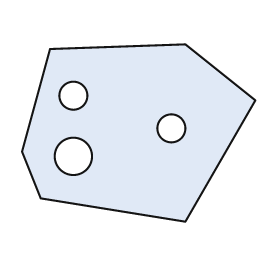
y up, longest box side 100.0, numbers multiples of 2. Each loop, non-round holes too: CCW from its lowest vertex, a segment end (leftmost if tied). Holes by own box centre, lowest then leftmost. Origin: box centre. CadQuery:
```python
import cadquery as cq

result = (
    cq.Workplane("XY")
    .moveTo(20.0, -38.0)
    .lineTo(50.0, 14.0)
    .lineTo(20.0, 38.0)
    .lineTo(-38.0, 36.0)
    .lineTo(-50.0, -8.0)
    .lineTo(-42.0, -28.0)
    .close()
    .moveTo(-28.0, -10.0)
    .circle(8.0)
    .moveTo(14.0, 2.0)
    .circle(6.0)
    .moveTo(-28.0, 16.0)
    .circle(6.0)
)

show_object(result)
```